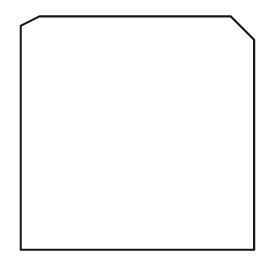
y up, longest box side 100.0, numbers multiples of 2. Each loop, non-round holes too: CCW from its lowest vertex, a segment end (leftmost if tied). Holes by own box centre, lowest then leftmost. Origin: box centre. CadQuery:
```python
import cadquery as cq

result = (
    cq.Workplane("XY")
    .moveTo(-50.0, -50.0)
    .lineTo(50.0, -50.0)
    .lineTo(50.0, 40.0)
    .lineTo(40.0, 50.0)
    .lineTo(-42.0, 50.0)
    .lineTo(-50.0, 46.0)
    .close()
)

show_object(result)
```